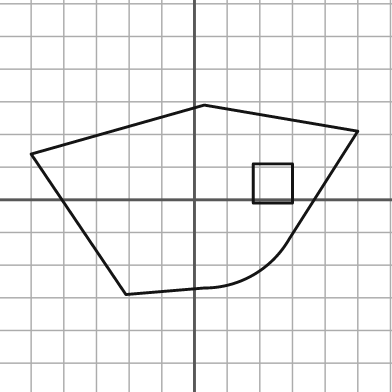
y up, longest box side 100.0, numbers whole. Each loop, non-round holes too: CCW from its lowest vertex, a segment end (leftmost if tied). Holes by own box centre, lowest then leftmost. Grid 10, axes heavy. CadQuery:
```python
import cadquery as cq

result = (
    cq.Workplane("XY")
    .moveTo(-21.0, -29.0)
    .lineTo(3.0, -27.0)
    .threePointArc((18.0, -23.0), (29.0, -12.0))
    .lineTo(50.0, 21.0)
    .lineTo(3.0, 29.0)
    .lineTo(-50.0, 14.0)
    .close()
    .moveTo(18.0, -1.0)
    .lineTo(30.0, -1.0)
    .lineTo(30.0, 11.0)
    .lineTo(18.0, 11.0)
    .close()
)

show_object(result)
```